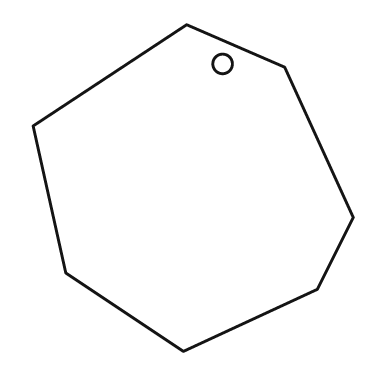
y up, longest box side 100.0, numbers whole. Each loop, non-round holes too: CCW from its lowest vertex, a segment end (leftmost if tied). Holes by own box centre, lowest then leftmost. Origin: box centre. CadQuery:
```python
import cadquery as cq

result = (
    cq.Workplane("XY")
    .moveTo(-3.0, -50.0)
    .lineTo(38.0, -31.0)
    .lineTo(49.0, -9.0)
    .lineTo(28.0, 37.0)
    .lineTo(-2.0, 50.0)
    .lineTo(-49.0, 19.0)
    .lineTo(-39.0, -26.0)
    .close()
    .moveTo(9.0, 38.0)
    .circle(3.0)
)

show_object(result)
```